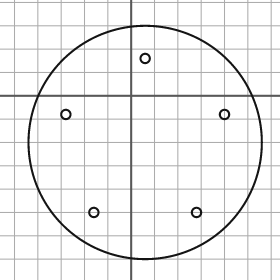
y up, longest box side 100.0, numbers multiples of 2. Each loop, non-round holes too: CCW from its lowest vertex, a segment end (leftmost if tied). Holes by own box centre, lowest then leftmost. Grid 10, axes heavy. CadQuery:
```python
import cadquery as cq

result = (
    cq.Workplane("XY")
    .moveTo(6.0, -20.0)
    .circle(50.0)
    .moveTo(-16.0, -50.0)
    .circle(2.0)
    .moveTo(28.0, -50.0)
    .circle(2.0)
    .moveTo(-28.0, -8.0)
    .circle(2.0)
    .moveTo(40.0, -8.0)
    .circle(2.0)
    .moveTo(6.0, 16.0)
    .circle(2.0)
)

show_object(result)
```